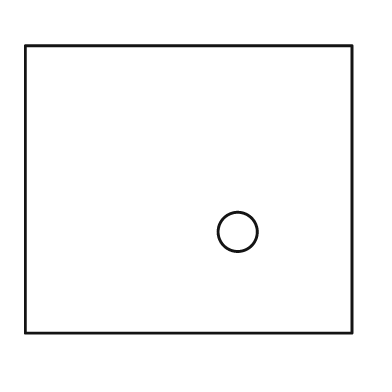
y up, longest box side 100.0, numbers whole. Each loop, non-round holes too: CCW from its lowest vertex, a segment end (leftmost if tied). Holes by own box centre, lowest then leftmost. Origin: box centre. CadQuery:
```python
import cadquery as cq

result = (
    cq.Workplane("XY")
    .moveTo(-50.0, -44.0)
    .lineTo(50.0, -44.0)
    .lineTo(50.0, 44.0)
    .lineTo(-50.0, 44.0)
    .close()
    .moveTo(15.0, -13.0)
    .circle(6.0)
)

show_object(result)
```